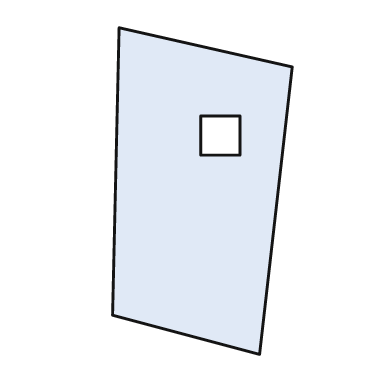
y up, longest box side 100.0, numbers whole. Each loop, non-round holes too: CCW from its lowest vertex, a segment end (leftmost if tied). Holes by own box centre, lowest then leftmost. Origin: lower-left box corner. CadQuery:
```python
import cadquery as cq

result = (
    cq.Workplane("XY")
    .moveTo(45.0, 0.0)
    .lineTo(55.0, 88.0)
    .lineTo(2.0, 100.0)
    .lineTo(0.0, 12.0)
    .close()
    .moveTo(27.0, 61.0)
    .lineTo(39.0, 61.0)
    .lineTo(39.0, 73.0)
    .lineTo(27.0, 73.0)
    .close()
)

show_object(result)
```